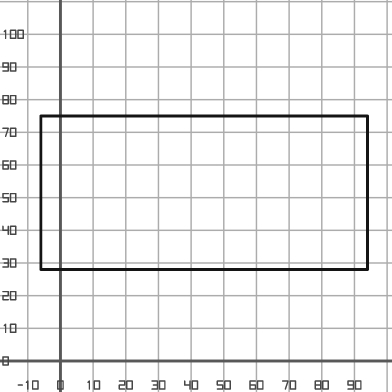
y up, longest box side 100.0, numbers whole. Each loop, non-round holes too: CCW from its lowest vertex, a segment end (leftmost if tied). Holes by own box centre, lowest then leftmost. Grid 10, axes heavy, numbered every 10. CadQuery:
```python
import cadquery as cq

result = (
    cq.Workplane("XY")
    .moveTo(-6.0, 28.0)
    .lineTo(94.0, 28.0)
    .lineTo(94.0, 75.0)
    .lineTo(-6.0, 75.0)
    .close()
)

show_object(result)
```